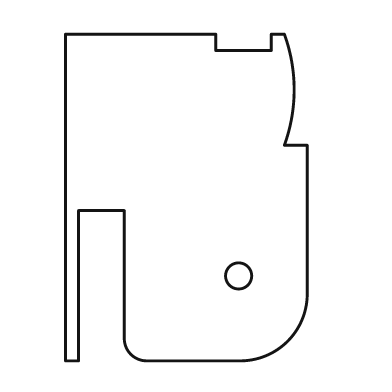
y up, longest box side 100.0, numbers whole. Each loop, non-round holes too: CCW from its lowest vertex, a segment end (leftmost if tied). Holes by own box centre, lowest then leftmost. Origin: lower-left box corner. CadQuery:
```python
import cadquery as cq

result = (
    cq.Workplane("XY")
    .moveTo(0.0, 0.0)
    .lineTo(4.0, 0.0)
    .lineTo(4.0, 46.0)
    .lineTo(18.0, 46.0)
    .lineTo(18.0, 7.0)
    .threePointArc((20.0, 2.0), (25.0, 0.0))
    .lineTo(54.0, 0.0)
    .threePointArc((68.0, 6.0), (74.0, 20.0))
    .lineTo(74.0, 66.0)
    .lineTo(67.0, 66.0)
    .threePointArc((70.0, 83.0), (67.0, 100.0))
    .lineTo(63.0, 100.0)
    .lineTo(63.0, 95.0)
    .lineTo(46.0, 95.0)
    .lineTo(46.0, 100.0)
    .lineTo(0.0, 100.0)
    .close()
    .moveTo(53.0, 26.0)
    .circle(4.0)
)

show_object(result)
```